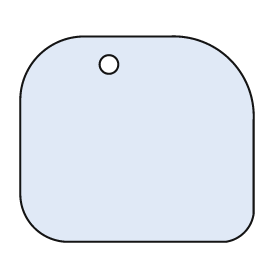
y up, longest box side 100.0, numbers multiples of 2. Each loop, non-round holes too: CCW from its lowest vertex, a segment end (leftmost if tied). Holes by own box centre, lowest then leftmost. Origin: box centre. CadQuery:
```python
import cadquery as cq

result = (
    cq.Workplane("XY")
    .moveTo(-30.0, -44.0)
    .lineTo(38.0, -44.0)
    .threePointArc((46.0, -40.0), (50.0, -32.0))
    .lineTo(50.0, 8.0)
    .threePointArc((40.0, 34.0), (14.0, 44.0))
    .lineTo(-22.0, 44.0)
    .threePointArc((-42.0, 36.0), (-50.0, 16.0))
    .lineTo(-50.0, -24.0)
    .threePointArc((-44.0, -38.0), (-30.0, -44.0))
    .close()
    .moveTo(-12.0, 32.0)
    .circle(4.0)
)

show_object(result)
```